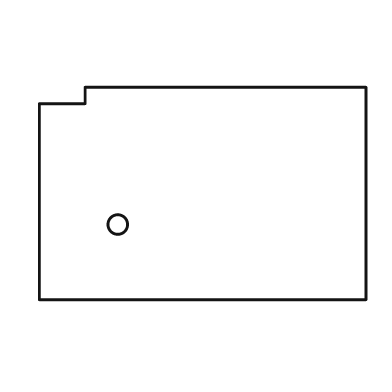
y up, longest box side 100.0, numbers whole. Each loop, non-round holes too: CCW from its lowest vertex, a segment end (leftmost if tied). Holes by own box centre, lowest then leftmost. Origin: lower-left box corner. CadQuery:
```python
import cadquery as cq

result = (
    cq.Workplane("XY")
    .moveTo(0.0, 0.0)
    .lineTo(100.0, 0.0)
    .lineTo(100.0, 65.0)
    .lineTo(14.0, 65.0)
    .lineTo(14.0, 60.0)
    .lineTo(0.0, 60.0)
    .close()
    .moveTo(24.0, 23.0)
    .circle(3.0)
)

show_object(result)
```